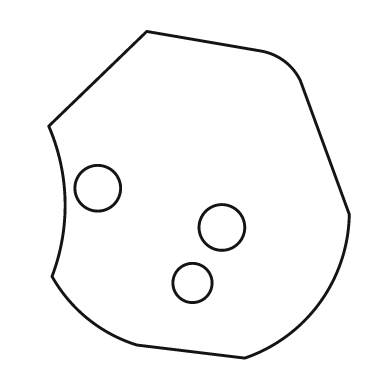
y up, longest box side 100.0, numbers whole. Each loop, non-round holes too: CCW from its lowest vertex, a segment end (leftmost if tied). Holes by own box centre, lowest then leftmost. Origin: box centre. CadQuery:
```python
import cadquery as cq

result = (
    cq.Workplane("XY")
    .moveTo(14.0, -50.0)
    .threePointArc((37.0, -33.0), (46.0, -6.0))
    .lineTo(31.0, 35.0)
    .threePointArc((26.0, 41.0), (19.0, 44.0))
    .lineTo(-16.0, 50.0)
    .lineTo(-46.0, 21.0)
    .threePointArc((-41.0, -2.0), (-45.0, -25.0))
    .threePointArc((-34.0, -38.0), (-19.0, -46.0))
    .close()
    .moveTo(-2.0, -27.0)
    .circle(6.0)
    .moveTo(7.0, -10.0)
    .circle(7.0)
    .moveTo(-31.0, 2.0)
    .circle(7.0)
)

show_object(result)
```